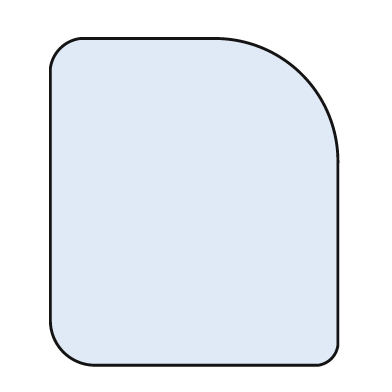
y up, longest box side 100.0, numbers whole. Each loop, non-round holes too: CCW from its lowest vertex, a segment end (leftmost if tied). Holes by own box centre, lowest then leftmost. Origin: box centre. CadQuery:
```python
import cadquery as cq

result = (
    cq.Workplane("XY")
    .moveTo(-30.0, -50.0)
    .lineTo(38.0, -50.0)
    .threePointArc((42.0, -48.0), (44.0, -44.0))
    .lineTo(44.0, 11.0)
    .threePointArc((33.0, 39.0), (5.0, 50.0))
    .lineTo(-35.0, 50.0)
    .threePointArc((-41.0, 47.0), (-44.0, 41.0))
    .lineTo(-44.0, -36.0)
    .threePointArc((-40.0, -46.0), (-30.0, -50.0))
    .close()
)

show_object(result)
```